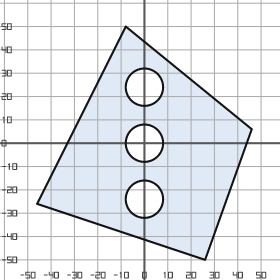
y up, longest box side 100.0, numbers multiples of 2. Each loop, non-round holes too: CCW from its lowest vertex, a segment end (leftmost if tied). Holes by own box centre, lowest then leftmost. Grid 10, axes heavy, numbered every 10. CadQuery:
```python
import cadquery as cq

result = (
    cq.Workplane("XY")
    .moveTo(26.0, -50.0)
    .lineTo(46.0, 6.0)
    .lineTo(-8.0, 50.0)
    .lineTo(-46.0, -26.0)
    .close()
    .moveTo(0.0, -24.0)
    .circle(8.0)
    .moveTo(0.0, 0.0)
    .circle(8.0)
    .moveTo(0.0, 24.0)
    .circle(8.0)
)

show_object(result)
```